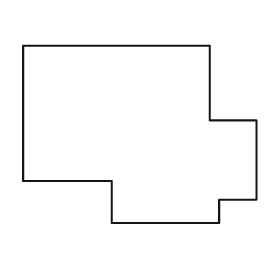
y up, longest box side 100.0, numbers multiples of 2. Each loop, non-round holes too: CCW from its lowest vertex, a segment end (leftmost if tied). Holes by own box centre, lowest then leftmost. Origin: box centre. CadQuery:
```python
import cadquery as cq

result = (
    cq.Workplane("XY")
    .moveTo(-12.0, -38.0)
    .lineTo(34.0, -38.0)
    .lineTo(34.0, -28.0)
    .lineTo(50.0, -28.0)
    .lineTo(50.0, 6.0)
    .lineTo(30.0, 6.0)
    .lineTo(30.0, 38.0)
    .lineTo(-50.0, 38.0)
    .lineTo(-50.0, -20.0)
    .lineTo(-12.0, -20.0)
    .close()
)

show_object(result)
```